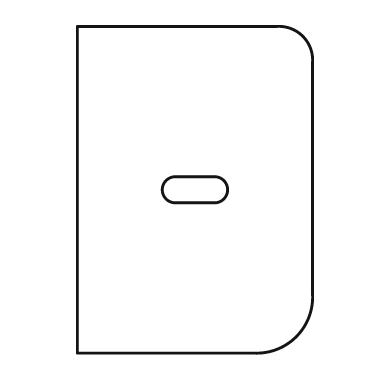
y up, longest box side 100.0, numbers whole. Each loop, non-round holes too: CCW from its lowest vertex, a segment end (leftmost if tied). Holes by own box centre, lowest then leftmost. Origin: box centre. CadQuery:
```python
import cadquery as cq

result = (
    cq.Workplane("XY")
    .moveTo(-36.0, -50.0)
    .lineTo(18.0, -50.0)
    .threePointArc((31.0, -45.0), (36.0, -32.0))
    .lineTo(36.0, 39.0)
    .threePointArc((33.0, 47.0), (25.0, 50.0))
    .lineTo(-36.0, 50.0)
    .close()
    .moveTo(-6.0, -4.0)
    .lineTo(6.0, -4.0)
    .threePointArc((10.0, 0.0), (6.0, 4.0))
    .lineTo(-6.0, 4.0)
    .threePointArc((-10.0, 0.0), (-6.0, -4.0))
    .close()
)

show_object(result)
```